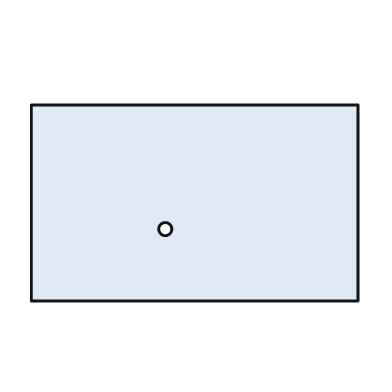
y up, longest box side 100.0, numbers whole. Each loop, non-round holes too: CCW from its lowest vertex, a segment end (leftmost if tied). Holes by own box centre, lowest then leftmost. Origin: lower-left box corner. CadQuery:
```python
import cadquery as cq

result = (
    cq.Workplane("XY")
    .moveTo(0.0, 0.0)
    .lineTo(100.0, 0.0)
    .lineTo(100.0, 60.0)
    .lineTo(0.0, 60.0)
    .close()
    .moveTo(41.0, 22.0)
    .circle(2.0)
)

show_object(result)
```